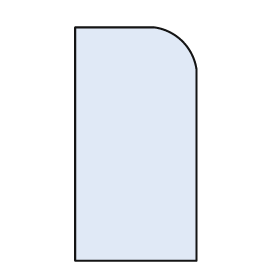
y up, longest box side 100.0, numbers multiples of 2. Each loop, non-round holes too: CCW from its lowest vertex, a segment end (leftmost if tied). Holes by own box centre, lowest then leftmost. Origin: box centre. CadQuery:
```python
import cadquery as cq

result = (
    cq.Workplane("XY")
    .moveTo(-26.0, -50.0)
    .lineTo(26.0, -50.0)
    .lineTo(26.0, 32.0)
    .threePointArc((20.0, 44.0), (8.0, 50.0))
    .lineTo(-26.0, 50.0)
    .close()
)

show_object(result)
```